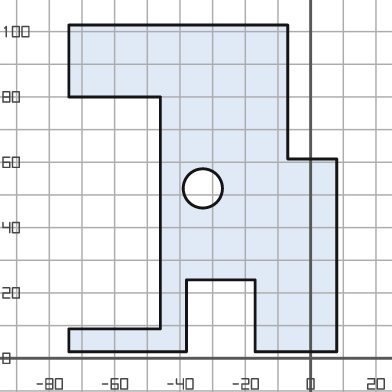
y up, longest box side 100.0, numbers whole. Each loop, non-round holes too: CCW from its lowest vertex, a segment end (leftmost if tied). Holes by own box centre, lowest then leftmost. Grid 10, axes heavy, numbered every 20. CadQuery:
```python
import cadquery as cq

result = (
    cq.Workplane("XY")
    .moveTo(-74.0, 2.0)
    .lineTo(-38.0, 2.0)
    .lineTo(-38.0, 24.0)
    .lineTo(-17.0, 24.0)
    .lineTo(-17.0, 2.0)
    .lineTo(8.0, 2.0)
    .lineTo(8.0, 61.0)
    .lineTo(-7.0, 61.0)
    .lineTo(-7.0, 102.0)
    .lineTo(-74.0, 102.0)
    .lineTo(-74.0, 80.0)
    .lineTo(-46.0, 80.0)
    .lineTo(-46.0, 9.0)
    .lineTo(-74.0, 9.0)
    .close()
    .moveTo(-33.0, 52.0)
    .circle(6.0)
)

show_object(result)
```